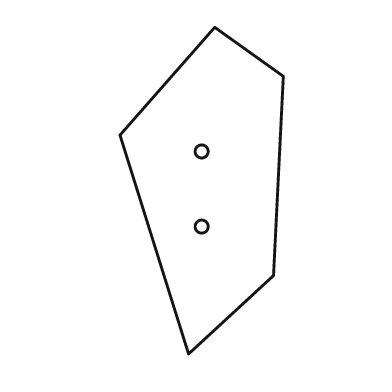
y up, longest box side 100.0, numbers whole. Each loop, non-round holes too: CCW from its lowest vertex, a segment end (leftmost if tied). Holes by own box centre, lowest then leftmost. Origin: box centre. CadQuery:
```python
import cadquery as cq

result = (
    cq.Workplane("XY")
    .moveTo(-4.0, -50.0)
    .lineTo(22.0, -26.0)
    .lineTo(25.0, 35.0)
    .lineTo(4.0, 50.0)
    .lineTo(-25.0, 17.0)
    .close()
    .moveTo(0.0, -11.0)
    .circle(2.0)
    .moveTo(0.0, 12.0)
    .circle(2.0)
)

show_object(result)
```